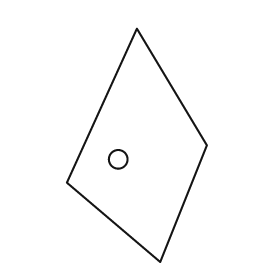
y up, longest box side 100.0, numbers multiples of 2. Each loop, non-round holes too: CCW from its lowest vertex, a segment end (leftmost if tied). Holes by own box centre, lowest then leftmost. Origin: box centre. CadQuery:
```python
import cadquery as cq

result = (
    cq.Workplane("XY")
    .moveTo(10.0, -50.0)
    .lineTo(30.0, 0.0)
    .lineTo(0.0, 50.0)
    .lineTo(-30.0, -16.0)
    .close()
    .moveTo(-8.0, -6.0)
    .circle(4.0)
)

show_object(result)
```